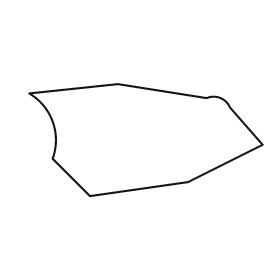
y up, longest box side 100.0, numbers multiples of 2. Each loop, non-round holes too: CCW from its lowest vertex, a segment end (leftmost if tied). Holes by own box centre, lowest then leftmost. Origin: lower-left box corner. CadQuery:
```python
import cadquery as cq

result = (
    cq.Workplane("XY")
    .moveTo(26.0, 0.0)
    .lineTo(68.0, 6.0)
    .lineTo(100.0, 22.0)
    .lineTo(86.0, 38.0)
    .threePointArc((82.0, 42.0), (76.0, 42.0))
    .lineTo(38.0, 48.0)
    .lineTo(0.0, 44.0)
    .threePointArc((10.0, 32.0), (10.0, 16.0))
    .close()
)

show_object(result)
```